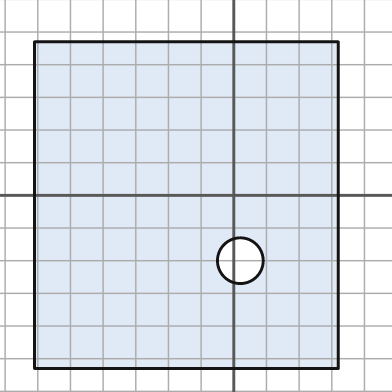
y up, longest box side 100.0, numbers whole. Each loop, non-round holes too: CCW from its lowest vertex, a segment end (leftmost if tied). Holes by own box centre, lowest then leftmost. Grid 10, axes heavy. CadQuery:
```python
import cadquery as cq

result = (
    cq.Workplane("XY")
    .moveTo(-61.0, -53.0)
    .lineTo(32.0, -53.0)
    .lineTo(32.0, 47.0)
    .lineTo(-61.0, 47.0)
    .close()
    .moveTo(2.0, -20.0)
    .circle(7.0)
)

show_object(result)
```